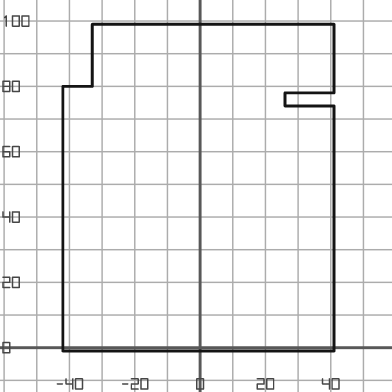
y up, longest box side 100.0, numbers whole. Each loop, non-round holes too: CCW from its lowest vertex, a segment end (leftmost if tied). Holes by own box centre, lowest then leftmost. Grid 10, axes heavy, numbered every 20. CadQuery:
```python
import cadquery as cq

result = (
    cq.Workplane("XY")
    .moveTo(-42.0, -1.0)
    .lineTo(41.0, -1.0)
    .lineTo(41.0, 74.0)
    .lineTo(26.0, 74.0)
    .lineTo(26.0, 78.0)
    .lineTo(41.0, 78.0)
    .lineTo(41.0, 99.0)
    .lineTo(-33.0, 99.0)
    .lineTo(-33.0, 80.0)
    .lineTo(-42.0, 80.0)
    .close()
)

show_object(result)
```